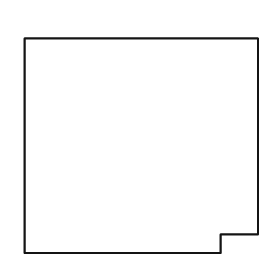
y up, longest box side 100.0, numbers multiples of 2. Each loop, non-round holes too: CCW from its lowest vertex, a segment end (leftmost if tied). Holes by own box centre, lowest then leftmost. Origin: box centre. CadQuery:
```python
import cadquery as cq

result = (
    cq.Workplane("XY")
    .moveTo(-50.0, -46.0)
    .lineTo(34.0, -46.0)
    .lineTo(34.0, -38.0)
    .lineTo(50.0, -38.0)
    .lineTo(50.0, 46.0)
    .lineTo(-50.0, 46.0)
    .close()
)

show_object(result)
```